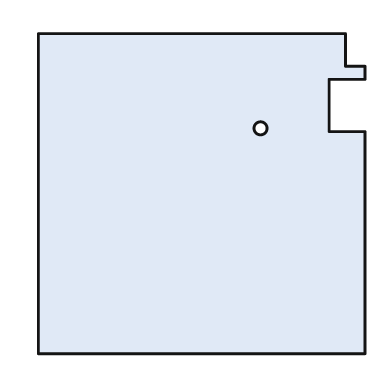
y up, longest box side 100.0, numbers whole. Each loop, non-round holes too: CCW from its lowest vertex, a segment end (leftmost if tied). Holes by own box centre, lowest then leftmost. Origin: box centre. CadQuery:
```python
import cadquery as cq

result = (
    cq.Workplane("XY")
    .moveTo(-50.0, -49.0)
    .lineTo(50.0, -49.0)
    .lineTo(50.0, 19.0)
    .lineTo(39.0, 19.0)
    .lineTo(39.0, 35.0)
    .lineTo(50.0, 35.0)
    .lineTo(50.0, 39.0)
    .lineTo(44.0, 39.0)
    .lineTo(44.0, 49.0)
    .lineTo(-50.0, 49.0)
    .close()
    .moveTo(18.0, 20.0)
    .circle(2.0)
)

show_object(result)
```